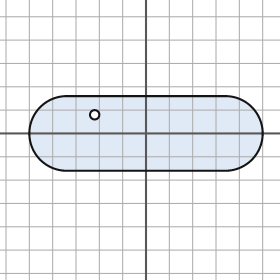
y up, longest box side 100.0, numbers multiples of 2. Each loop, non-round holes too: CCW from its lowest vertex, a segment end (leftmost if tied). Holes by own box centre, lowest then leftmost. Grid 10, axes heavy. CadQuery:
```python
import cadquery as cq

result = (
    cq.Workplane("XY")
    .moveTo(-34.0, -16.0)
    .lineTo(34.0, -16.0)
    .threePointArc((50.0, 0.0), (34.0, 16.0))
    .lineTo(-34.0, 16.0)
    .threePointArc((-50.0, 0.0), (-34.0, -16.0))
    .close()
    .moveTo(-22.0, 8.0)
    .circle(2.0)
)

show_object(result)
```